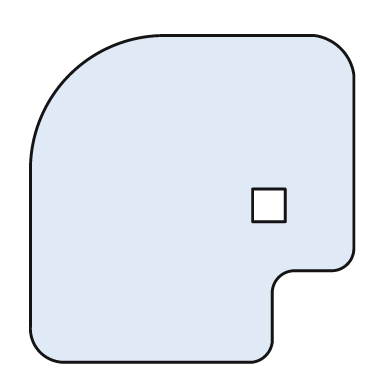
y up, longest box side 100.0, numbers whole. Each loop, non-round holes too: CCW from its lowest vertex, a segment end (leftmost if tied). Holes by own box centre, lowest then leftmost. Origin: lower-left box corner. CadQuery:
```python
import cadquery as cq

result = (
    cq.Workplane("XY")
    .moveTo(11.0, 0.0)
    .lineTo(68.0, 0.0)
    .threePointArc((72.0, 2.0), (74.0, 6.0))
    .lineTo(74.0, 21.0)
    .threePointArc((76.0, 26.0), (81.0, 28.0))
    .lineTo(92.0, 28.0)
    .threePointArc((97.0, 30.0), (99.0, 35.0))
    .lineTo(99.0, 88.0)
    .threePointArc((95.0, 96.0), (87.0, 100.0))
    .lineTo(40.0, 100.0)
    .threePointArc((12.0, 88.0), (0.0, 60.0))
    .lineTo(0.0, 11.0)
    .threePointArc((3.0, 3.0), (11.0, 0.0))
    .close()
    .moveTo(68.0, 43.0)
    .lineTo(78.0, 43.0)
    .lineTo(78.0, 53.0)
    .lineTo(68.0, 53.0)
    .close()
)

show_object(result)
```